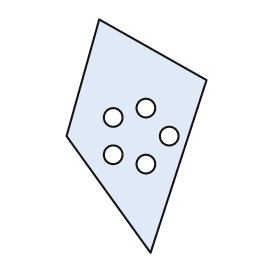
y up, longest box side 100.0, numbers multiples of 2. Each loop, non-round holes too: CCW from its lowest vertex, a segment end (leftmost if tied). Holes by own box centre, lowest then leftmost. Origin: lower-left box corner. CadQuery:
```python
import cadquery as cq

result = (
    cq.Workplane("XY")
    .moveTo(36.0, 0.0)
    .lineTo(60.0, 74.0)
    .lineTo(14.0, 100.0)
    .lineTo(0.0, 50.0)
    .close()
    .moveTo(34.0, 38.0)
    .circle(4.0)
    .moveTo(20.0, 42.0)
    .circle(4.0)
    .moveTo(44.0, 50.0)
    .circle(4.0)
    .moveTo(20.0, 58.0)
    .circle(4.0)
    .moveTo(34.0, 62.0)
    .circle(4.0)
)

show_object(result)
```